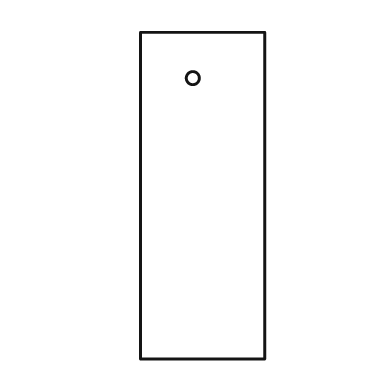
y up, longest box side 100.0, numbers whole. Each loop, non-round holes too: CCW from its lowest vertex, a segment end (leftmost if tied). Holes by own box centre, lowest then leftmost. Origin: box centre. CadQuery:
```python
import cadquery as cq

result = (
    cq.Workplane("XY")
    .moveTo(-19.0, -50.0)
    .lineTo(19.0, -50.0)
    .lineTo(19.0, 50.0)
    .lineTo(-19.0, 50.0)
    .close()
    .moveTo(-3.0, 36.0)
    .circle(2.0)
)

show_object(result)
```